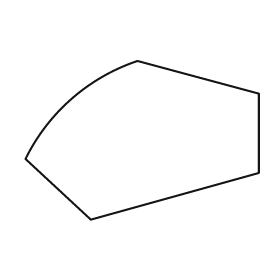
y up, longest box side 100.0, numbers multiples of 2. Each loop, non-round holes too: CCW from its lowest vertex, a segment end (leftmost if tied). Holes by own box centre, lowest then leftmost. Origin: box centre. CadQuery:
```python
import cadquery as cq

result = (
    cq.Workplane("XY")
    .moveTo(-22.0, -34.0)
    .lineTo(50.0, -14.0)
    .lineTo(50.0, 20.0)
    .lineTo(-2.0, 34.0)
    .threePointArc((-30.0, 18.0), (-50.0, -8.0))
    .close()
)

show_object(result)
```